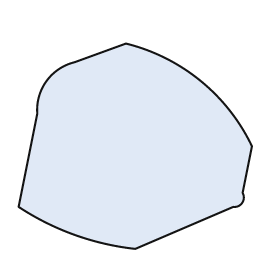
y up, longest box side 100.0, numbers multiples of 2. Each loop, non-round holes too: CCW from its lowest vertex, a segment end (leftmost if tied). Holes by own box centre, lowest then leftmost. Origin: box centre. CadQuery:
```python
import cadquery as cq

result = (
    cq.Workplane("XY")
    .moveTo(0.0, -44.0)
    .lineTo(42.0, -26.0)
    .threePointArc((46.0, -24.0), (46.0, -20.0))
    .lineTo(50.0, 0.0)
    .threePointArc((28.0, 28.0), (-4.0, 44.0))
    .lineTo(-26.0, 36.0)
    .threePointArc((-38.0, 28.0), (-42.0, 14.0))
    .lineTo(-50.0, -26.0)
    .threePointArc((-26.0, -38.0), (0.0, -44.0))
    .close()
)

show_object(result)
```